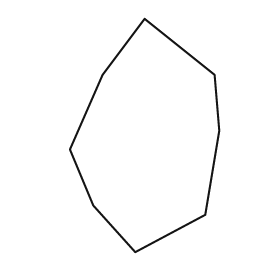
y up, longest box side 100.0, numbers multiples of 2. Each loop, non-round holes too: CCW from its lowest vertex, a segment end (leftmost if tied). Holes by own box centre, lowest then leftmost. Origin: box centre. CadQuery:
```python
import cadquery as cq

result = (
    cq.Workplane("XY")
    .moveTo(-4.0, -50.0)
    .lineTo(26.0, -34.0)
    .lineTo(32.0, 2.0)
    .lineTo(30.0, 26.0)
    .lineTo(0.0, 50.0)
    .lineTo(-18.0, 26.0)
    .lineTo(-32.0, -6.0)
    .lineTo(-22.0, -30.0)
    .close()
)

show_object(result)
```